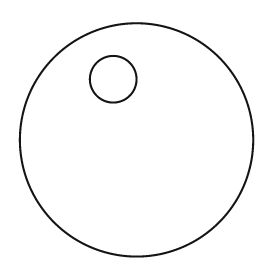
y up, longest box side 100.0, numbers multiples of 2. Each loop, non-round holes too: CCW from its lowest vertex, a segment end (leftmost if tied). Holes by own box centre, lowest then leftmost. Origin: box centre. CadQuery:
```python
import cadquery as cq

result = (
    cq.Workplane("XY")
    .moveTo(0.0, 0.0)
    .circle(50.0)
    .moveTo(-10.0, 26.0)
    .circle(10.0)
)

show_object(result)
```